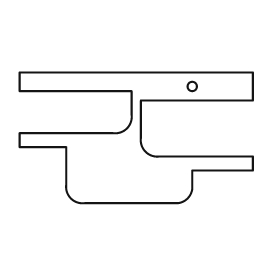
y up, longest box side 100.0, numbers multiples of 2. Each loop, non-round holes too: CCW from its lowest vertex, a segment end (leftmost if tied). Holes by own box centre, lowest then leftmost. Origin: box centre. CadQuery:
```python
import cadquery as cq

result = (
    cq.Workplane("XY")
    .moveTo(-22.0, -28.0)
    .lineTo(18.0, -28.0)
    .threePointArc((22.0, -26.0), (24.0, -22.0))
    .lineTo(24.0, -14.0)
    .lineTo(50.0, -14.0)
    .lineTo(50.0, -8.0)
    .lineTo(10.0, -8.0)
    .threePointArc((4.0, -6.0), (2.0, 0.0))
    .lineTo(2.0, 16.0)
    .lineTo(50.0, 16.0)
    .lineTo(50.0, 28.0)
    .lineTo(-50.0, 28.0)
    .lineTo(-50.0, 20.0)
    .lineTo(-2.0, 20.0)
    .lineTo(-2.0, 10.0)
    .threePointArc((-4.0, 4.0), (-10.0, 2.0))
    .lineTo(-50.0, 2.0)
    .lineTo(-50.0, -4.0)
    .lineTo(-30.0, -4.0)
    .lineTo(-30.0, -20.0)
    .threePointArc((-28.0, -26.0), (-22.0, -28.0))
    .close()
    .moveTo(24.0, 22.0)
    .circle(2.0)
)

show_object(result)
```